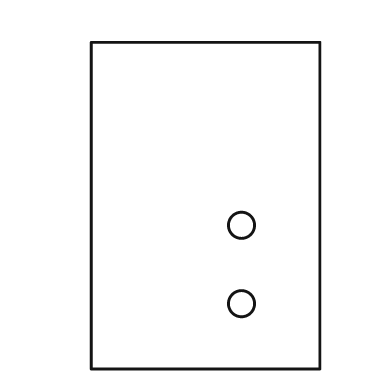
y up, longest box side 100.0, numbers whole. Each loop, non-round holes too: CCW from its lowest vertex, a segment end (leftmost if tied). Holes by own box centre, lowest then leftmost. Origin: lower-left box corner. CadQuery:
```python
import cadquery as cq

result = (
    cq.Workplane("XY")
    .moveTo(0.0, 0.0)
    .lineTo(70.0, 0.0)
    .lineTo(70.0, 100.0)
    .lineTo(0.0, 100.0)
    .close()
    .moveTo(46.0, 20.0)
    .circle(4.0)
    .moveTo(46.0, 44.0)
    .circle(4.0)
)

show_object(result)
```